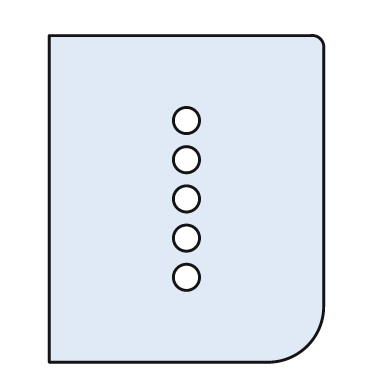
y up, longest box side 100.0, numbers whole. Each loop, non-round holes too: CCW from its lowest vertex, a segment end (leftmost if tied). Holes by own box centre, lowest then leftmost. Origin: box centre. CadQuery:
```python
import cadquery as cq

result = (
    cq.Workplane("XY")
    .moveTo(-42.0, -50.0)
    .lineTo(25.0, -50.0)
    .threePointArc((37.0, -45.0), (42.0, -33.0))
    .lineTo(42.0, 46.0)
    .threePointArc((41.0, 49.0), (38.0, 50.0))
    .lineTo(-42.0, 50.0)
    .close()
    .moveTo(0.0, -24.0)
    .circle(4.0)
    .moveTo(0.0, -12.0)
    .circle(4.0)
    .moveTo(0.0, 0.0)
    .circle(4.0)
    .moveTo(0.0, 12.0)
    .circle(4.0)
    .moveTo(0.0, 24.0)
    .circle(4.0)
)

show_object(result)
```